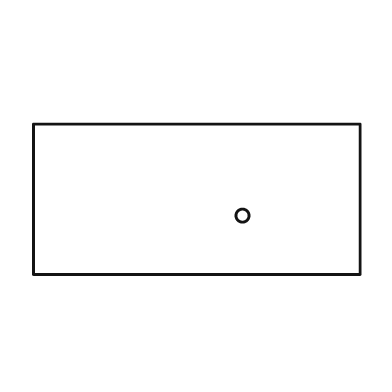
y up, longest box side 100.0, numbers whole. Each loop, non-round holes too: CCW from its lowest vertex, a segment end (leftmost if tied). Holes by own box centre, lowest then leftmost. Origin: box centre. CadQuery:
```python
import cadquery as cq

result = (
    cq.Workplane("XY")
    .moveTo(-50.0, -23.0)
    .lineTo(50.0, -23.0)
    .lineTo(50.0, 23.0)
    .lineTo(-50.0, 23.0)
    .close()
    .moveTo(14.0, -5.0)
    .circle(2.0)
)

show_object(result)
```